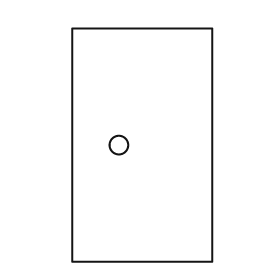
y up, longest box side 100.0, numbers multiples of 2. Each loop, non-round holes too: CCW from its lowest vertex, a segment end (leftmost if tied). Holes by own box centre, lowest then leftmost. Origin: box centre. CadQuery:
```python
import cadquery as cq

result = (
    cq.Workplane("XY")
    .moveTo(-30.0, -50.0)
    .lineTo(30.0, -50.0)
    .lineTo(30.0, 50.0)
    .lineTo(-30.0, 50.0)
    .close()
    .moveTo(-10.0, 0.0)
    .circle(4.0)
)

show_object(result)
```